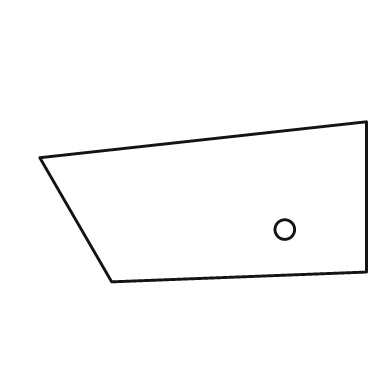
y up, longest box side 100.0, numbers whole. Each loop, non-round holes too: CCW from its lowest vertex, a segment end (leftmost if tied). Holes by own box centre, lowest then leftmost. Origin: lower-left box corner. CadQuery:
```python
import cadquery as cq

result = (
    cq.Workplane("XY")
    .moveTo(22.0, 0.0)
    .lineTo(100.0, 3.0)
    .lineTo(100.0, 49.0)
    .lineTo(0.0, 38.0)
    .close()
    .moveTo(75.0, 16.0)
    .circle(3.0)
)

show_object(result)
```